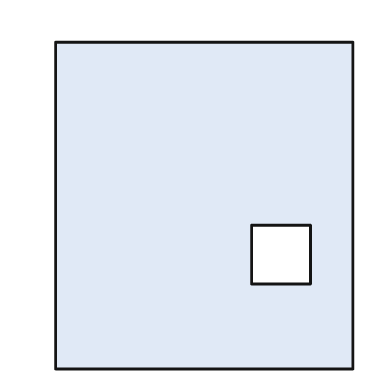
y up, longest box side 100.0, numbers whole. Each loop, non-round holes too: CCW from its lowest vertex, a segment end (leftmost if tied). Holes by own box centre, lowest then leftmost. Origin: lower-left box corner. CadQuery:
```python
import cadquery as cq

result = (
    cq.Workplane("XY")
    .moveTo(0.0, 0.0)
    .lineTo(91.0, 0.0)
    .lineTo(91.0, 100.0)
    .lineTo(0.0, 100.0)
    .close()
    .moveTo(60.0, 26.0)
    .lineTo(78.0, 26.0)
    .lineTo(78.0, 44.0)
    .lineTo(60.0, 44.0)
    .close()
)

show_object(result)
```